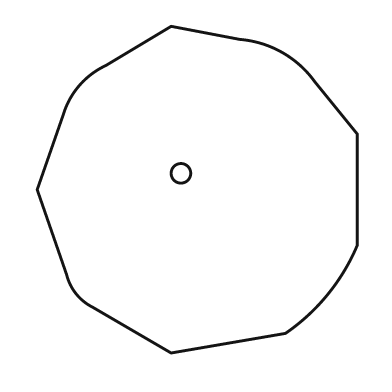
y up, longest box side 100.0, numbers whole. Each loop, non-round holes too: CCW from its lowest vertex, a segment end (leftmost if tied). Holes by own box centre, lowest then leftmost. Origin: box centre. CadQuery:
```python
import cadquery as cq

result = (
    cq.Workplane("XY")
    .moveTo(-8.0, -50.0)
    .lineTo(27.0, -44.0)
    .threePointArc((40.0, -32.0), (49.0, -17.0))
    .lineTo(49.0, 17.0)
    .lineTo(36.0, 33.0)
    .threePointArc((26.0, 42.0), (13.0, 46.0))
    .lineTo(-8.0, 50.0)
    .lineTo(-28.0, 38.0)
    .threePointArc((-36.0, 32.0), (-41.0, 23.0))
    .lineTo(-49.0, 0.0)
    .lineTo(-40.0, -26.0)
    .threePointArc((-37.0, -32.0), (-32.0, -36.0))
    .close()
    .moveTo(-5.0, 5.0)
    .circle(3.0)
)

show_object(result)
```